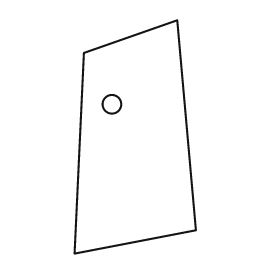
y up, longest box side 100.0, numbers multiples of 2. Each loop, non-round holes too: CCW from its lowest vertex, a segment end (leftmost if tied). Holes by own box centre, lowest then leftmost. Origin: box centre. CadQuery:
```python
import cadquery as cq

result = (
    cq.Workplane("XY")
    .moveTo(-26.0, -50.0)
    .lineTo(26.0, -40.0)
    .lineTo(18.0, 50.0)
    .lineTo(-22.0, 36.0)
    .close()
    .moveTo(-10.0, 14.0)
    .circle(4.0)
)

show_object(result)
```